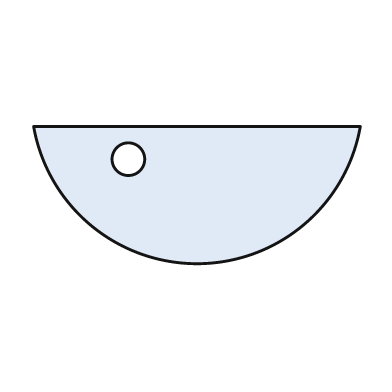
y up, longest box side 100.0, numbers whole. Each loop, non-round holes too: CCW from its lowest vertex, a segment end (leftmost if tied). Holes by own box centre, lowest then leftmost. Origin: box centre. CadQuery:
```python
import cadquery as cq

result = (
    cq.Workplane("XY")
    .moveTo(-50.0, 21.0)
    .threePointArc((0.0, -21.0), (50.0, 21.0))
    .close()
    .moveTo(-21.0, 11.0)
    .circle(5.0)
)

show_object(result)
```